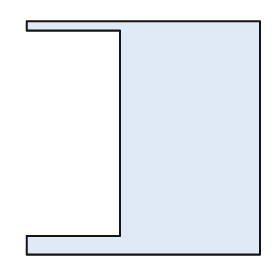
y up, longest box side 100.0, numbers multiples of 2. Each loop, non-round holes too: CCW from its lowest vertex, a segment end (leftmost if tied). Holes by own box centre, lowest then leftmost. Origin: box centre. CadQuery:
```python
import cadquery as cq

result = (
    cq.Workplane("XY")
    .moveTo(-50.0, -50.0)
    .lineTo(50.0, -50.0)
    .lineTo(50.0, 50.0)
    .lineTo(-50.0, 50.0)
    .lineTo(-50.0, 46.0)
    .lineTo(-10.0, 46.0)
    .lineTo(-10.0, -42.0)
    .lineTo(-50.0, -42.0)
    .close()
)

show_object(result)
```